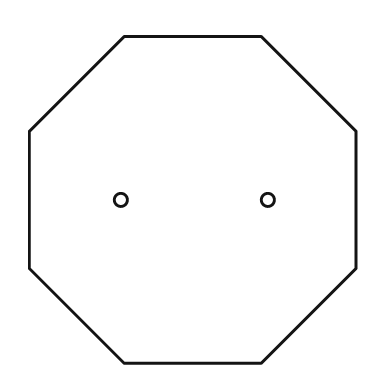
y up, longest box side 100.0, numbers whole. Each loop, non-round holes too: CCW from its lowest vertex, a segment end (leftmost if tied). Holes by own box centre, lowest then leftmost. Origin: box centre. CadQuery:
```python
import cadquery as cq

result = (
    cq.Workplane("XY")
    .moveTo(-21.0, -50.0)
    .lineTo(21.0, -50.0)
    .lineTo(50.0, -21.0)
    .lineTo(50.0, 21.0)
    .lineTo(21.0, 50.0)
    .lineTo(-21.0, 50.0)
    .lineTo(-50.0, 21.0)
    .lineTo(-50.0, -21.0)
    .close()
    .moveTo(-22.0, 0.0)
    .circle(2.0)
    .moveTo(23.0, 0.0)
    .circle(2.0)
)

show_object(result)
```